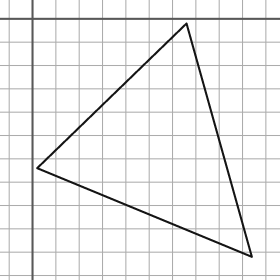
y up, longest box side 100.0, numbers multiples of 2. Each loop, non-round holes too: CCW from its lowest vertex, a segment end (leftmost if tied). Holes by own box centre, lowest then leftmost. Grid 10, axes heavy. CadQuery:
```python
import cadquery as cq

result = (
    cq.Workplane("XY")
    .moveTo(94.0, -102.0)
    .lineTo(66.0, -2.0)
    .lineTo(2.0, -64.0)
    .close()
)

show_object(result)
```